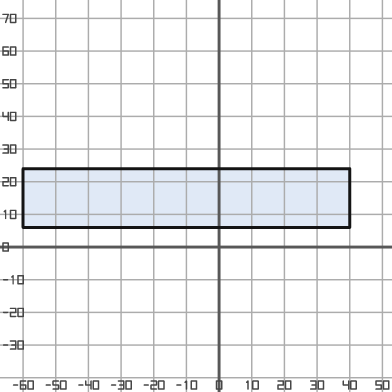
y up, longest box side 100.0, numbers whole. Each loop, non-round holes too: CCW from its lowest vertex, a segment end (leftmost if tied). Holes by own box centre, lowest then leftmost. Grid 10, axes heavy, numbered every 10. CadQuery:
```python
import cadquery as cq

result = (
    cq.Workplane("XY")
    .moveTo(-60.0, 6.0)
    .lineTo(40.0, 6.0)
    .lineTo(40.0, 24.0)
    .lineTo(-60.0, 24.0)
    .close()
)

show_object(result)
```